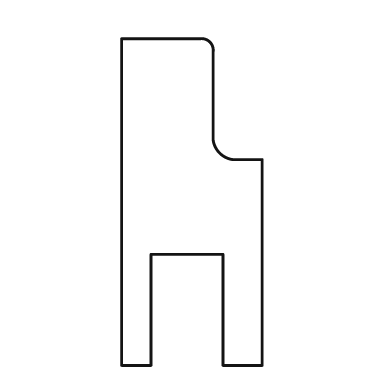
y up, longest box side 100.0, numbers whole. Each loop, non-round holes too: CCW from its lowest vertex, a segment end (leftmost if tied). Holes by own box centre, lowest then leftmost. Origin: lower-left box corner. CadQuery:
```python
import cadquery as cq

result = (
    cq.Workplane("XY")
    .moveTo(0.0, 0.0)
    .lineTo(9.0, 0.0)
    .lineTo(9.0, 34.0)
    .lineTo(31.0, 34.0)
    .lineTo(31.0, 0.0)
    .lineTo(43.0, 0.0)
    .lineTo(43.0, 63.0)
    .lineTo(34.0, 63.0)
    .threePointArc((30.0, 65.0), (28.0, 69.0))
    .lineTo(28.0, 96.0)
    .threePointArc((27.0, 99.0), (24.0, 100.0))
    .lineTo(0.0, 100.0)
    .close()
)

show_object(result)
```